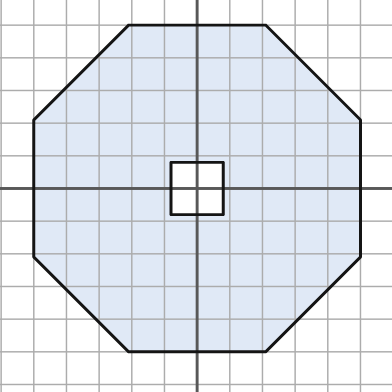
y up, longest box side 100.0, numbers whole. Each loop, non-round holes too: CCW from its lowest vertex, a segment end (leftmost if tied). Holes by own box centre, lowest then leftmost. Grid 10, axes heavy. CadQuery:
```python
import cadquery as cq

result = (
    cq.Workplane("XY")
    .moveTo(-21.0, -50.0)
    .lineTo(21.0, -50.0)
    .lineTo(50.0, -21.0)
    .lineTo(50.0, 21.0)
    .lineTo(21.0, 50.0)
    .lineTo(-21.0, 50.0)
    .lineTo(-50.0, 21.0)
    .lineTo(-50.0, -21.0)
    .close()
    .moveTo(-8.0, -8.0)
    .lineTo(8.0, -8.0)
    .lineTo(8.0, 8.0)
    .lineTo(-8.0, 8.0)
    .close()
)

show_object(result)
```